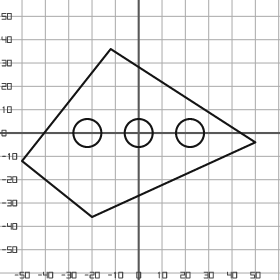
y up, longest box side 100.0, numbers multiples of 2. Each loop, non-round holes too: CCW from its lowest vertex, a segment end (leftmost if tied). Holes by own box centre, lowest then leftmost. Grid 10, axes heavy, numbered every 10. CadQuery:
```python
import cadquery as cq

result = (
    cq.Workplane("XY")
    .moveTo(-20.0, -36.0)
    .lineTo(50.0, -4.0)
    .lineTo(-12.0, 36.0)
    .lineTo(-50.0, -12.0)
    .close()
    .moveTo(-22.0, 0.0)
    .circle(6.0)
    .moveTo(0.0, 0.0)
    .circle(6.0)
    .moveTo(22.0, 0.0)
    .circle(6.0)
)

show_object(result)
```